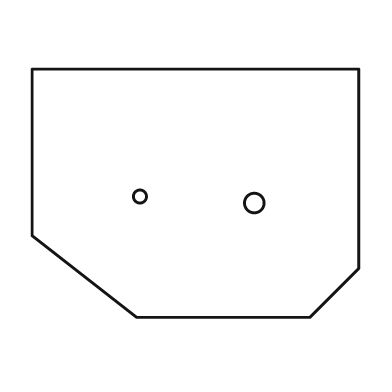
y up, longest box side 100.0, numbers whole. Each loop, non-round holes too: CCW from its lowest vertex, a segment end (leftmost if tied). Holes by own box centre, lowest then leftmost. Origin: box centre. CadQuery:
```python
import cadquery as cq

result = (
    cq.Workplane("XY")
    .moveTo(-18.0, -38.0)
    .lineTo(35.0, -38.0)
    .lineTo(50.0, -23.0)
    .lineTo(50.0, 38.0)
    .lineTo(-50.0, 38.0)
    .lineTo(-50.0, -13.0)
    .close()
    .moveTo(18.0, -3.0)
    .circle(3.0)
    .moveTo(-17.0, -1.0)
    .circle(2.0)
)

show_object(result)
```